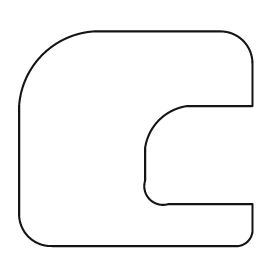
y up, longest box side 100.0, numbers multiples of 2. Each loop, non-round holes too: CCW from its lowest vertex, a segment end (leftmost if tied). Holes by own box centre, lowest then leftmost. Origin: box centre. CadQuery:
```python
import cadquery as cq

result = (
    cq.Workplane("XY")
    .moveTo(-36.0, -46.0)
    .lineTo(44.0, -46.0)
    .threePointArc((48.0, -44.0), (50.0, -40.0))
    .lineTo(50.0, -28.0)
    .lineTo(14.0, -28.0)
    .threePointArc((6.0, -26.0), (4.0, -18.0))
    .lineTo(4.0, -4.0)
    .threePointArc((10.0, 8.0), (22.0, 14.0))
    .lineTo(50.0, 14.0)
    .lineTo(50.0, 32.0)
    .threePointArc((46.0, 42.0), (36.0, 46.0))
    .lineTo(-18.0, 46.0)
    .threePointArc((-40.0, 36.0), (-50.0, 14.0))
    .lineTo(-50.0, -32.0)
    .threePointArc((-46.0, -42.0), (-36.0, -46.0))
    .close()
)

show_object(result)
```